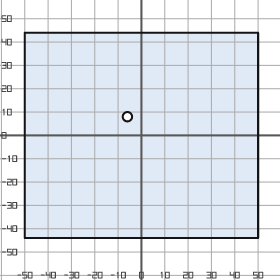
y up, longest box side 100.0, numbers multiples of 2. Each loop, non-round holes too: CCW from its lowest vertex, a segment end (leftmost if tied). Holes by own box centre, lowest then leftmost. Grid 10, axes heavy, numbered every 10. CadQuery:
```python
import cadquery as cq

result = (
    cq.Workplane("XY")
    .moveTo(-50.0, -44.0)
    .lineTo(50.0, -44.0)
    .lineTo(50.0, 44.0)
    .lineTo(-50.0, 44.0)
    .close()
    .moveTo(-6.0, 8.0)
    .circle(2.0)
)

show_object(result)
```